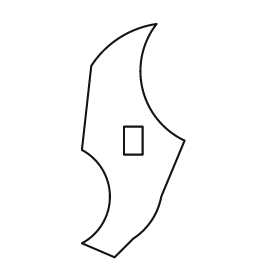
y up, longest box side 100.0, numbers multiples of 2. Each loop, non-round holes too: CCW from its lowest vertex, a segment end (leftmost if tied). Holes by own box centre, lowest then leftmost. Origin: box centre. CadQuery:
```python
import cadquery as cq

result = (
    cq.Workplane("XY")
    .moveTo(-8.0, -50.0)
    .lineTo(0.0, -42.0)
    .threePointArc((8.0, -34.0), (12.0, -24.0))
    .lineTo(22.0, 0.0)
    .threePointArc((4.0, 22.0), (10.0, 50.0))
    .threePointArc((-6.0, 44.0), (-18.0, 32.0))
    .lineTo(-22.0, -4.0)
    .threePointArc((-10.0, -24.0), (-22.0, -44.0))
    .close()
    .moveTo(-4.0, -6.0)
    .lineTo(4.0, -6.0)
    .lineTo(4.0, 6.0)
    .lineTo(-4.0, 6.0)
    .close()
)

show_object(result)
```